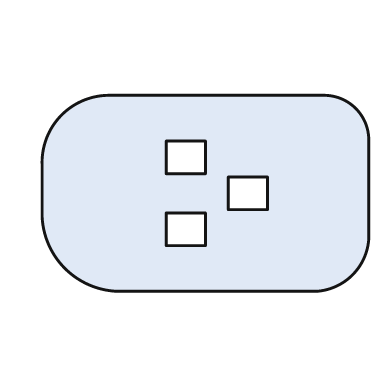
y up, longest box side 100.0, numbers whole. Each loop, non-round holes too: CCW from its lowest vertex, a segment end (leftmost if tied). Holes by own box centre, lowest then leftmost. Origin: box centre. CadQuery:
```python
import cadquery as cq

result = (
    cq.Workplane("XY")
    .moveTo(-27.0, -30.0)
    .lineTo(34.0, -30.0)
    .threePointArc((45.0, -25.0), (50.0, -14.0))
    .lineTo(50.0, 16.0)
    .threePointArc((46.0, 26.0), (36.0, 30.0))
    .lineTo(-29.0, 30.0)
    .threePointArc((-44.0, 24.0), (-50.0, 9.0))
    .lineTo(-50.0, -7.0)
    .threePointArc((-43.0, -23.0), (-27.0, -30.0))
    .close()
    .moveTo(-12.0, -16.0)
    .lineTo(0.0, -16.0)
    .lineTo(0.0, -6.0)
    .lineTo(-12.0, -6.0)
    .close()
    .moveTo(7.0, -5.0)
    .lineTo(19.0, -5.0)
    .lineTo(19.0, 5.0)
    .lineTo(7.0, 5.0)
    .close()
    .moveTo(-12.0, 6.0)
    .lineTo(0.0, 6.0)
    .lineTo(0.0, 16.0)
    .lineTo(-12.0, 16.0)
    .close()
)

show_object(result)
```